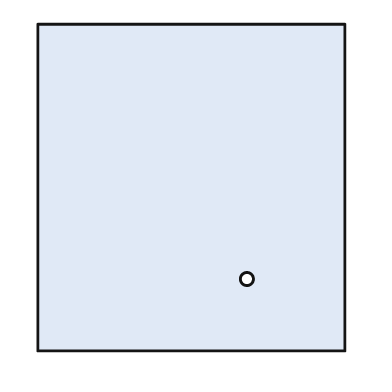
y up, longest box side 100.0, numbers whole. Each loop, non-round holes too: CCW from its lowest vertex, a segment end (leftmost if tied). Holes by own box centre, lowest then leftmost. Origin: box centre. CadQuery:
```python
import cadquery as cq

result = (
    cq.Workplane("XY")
    .moveTo(-47.0, -50.0)
    .lineTo(47.0, -50.0)
    .lineTo(47.0, 50.0)
    .lineTo(-47.0, 50.0)
    .close()
    .moveTo(17.0, -28.0)
    .circle(2.0)
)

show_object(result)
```